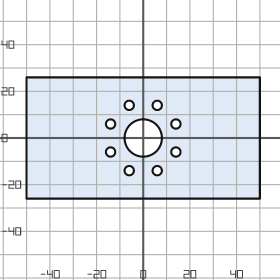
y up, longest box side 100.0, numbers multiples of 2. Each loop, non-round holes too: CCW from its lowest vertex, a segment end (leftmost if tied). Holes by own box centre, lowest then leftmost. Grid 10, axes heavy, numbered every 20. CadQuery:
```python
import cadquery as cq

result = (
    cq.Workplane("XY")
    .moveTo(-50.0, -26.0)
    .lineTo(50.0, -26.0)
    .lineTo(50.0, 26.0)
    .lineTo(-50.0, 26.0)
    .close()
    .moveTo(-6.0, -14.0)
    .circle(2.0)
    .moveTo(6.0, -14.0)
    .circle(2.0)
    .moveTo(-14.0, -6.0)
    .circle(2.0)
    .moveTo(14.0, -6.0)
    .circle(2.0)
    .moveTo(0.0, 0.0)
    .circle(8.0)
    .moveTo(-14.0, 6.0)
    .circle(2.0)
    .moveTo(14.0, 6.0)
    .circle(2.0)
    .moveTo(-6.0, 14.0)
    .circle(2.0)
    .moveTo(6.0, 14.0)
    .circle(2.0)
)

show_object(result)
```